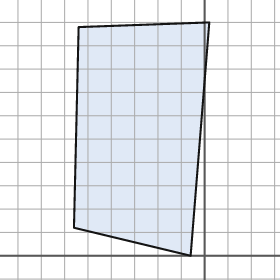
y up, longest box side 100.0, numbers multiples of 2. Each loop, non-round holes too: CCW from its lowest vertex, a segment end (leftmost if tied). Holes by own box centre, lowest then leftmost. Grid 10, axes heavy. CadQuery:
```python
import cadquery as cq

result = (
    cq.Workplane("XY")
    .moveTo(-6.0, 0.0)
    .lineTo(2.0, 100.0)
    .lineTo(-54.0, 98.0)
    .lineTo(-56.0, 12.0)
    .close()
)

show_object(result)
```